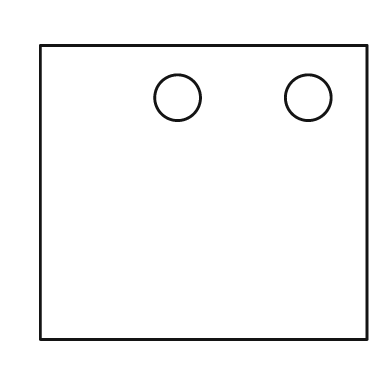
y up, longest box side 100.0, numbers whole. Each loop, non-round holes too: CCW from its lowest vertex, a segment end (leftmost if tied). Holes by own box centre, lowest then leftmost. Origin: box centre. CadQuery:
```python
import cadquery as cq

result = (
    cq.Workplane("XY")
    .moveTo(-50.0, -45.0)
    .lineTo(50.0, -45.0)
    .lineTo(50.0, 45.0)
    .lineTo(-50.0, 45.0)
    .close()
    .moveTo(-8.0, 29.0)
    .circle(7.0)
    .moveTo(32.0, 29.0)
    .circle(7.0)
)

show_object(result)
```